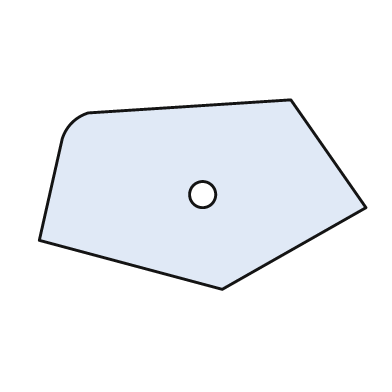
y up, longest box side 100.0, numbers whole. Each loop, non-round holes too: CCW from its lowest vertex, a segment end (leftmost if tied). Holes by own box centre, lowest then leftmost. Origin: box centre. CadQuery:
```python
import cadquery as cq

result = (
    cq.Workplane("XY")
    .moveTo(6.0, -29.0)
    .lineTo(50.0, -4.0)
    .lineTo(27.0, 29.0)
    .lineTo(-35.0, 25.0)
    .threePointArc((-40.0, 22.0), (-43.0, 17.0))
    .lineTo(-50.0, -14.0)
    .close()
    .moveTo(0.0, 0.0)
    .circle(4.0)
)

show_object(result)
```